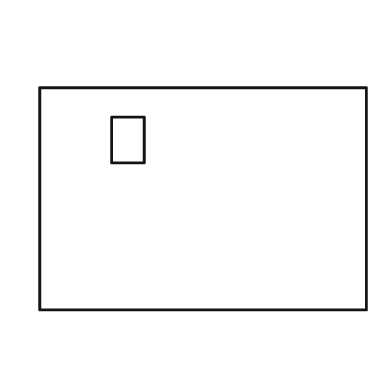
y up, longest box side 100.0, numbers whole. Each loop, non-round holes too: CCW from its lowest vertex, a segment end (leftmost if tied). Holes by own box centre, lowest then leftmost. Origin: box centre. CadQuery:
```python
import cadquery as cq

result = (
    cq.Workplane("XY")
    .moveTo(-50.0, -34.0)
    .lineTo(50.0, -34.0)
    .lineTo(50.0, 34.0)
    .lineTo(-50.0, 34.0)
    .close()
    .moveTo(-28.0, 11.0)
    .lineTo(-18.0, 11.0)
    .lineTo(-18.0, 25.0)
    .lineTo(-28.0, 25.0)
    .close()
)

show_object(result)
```